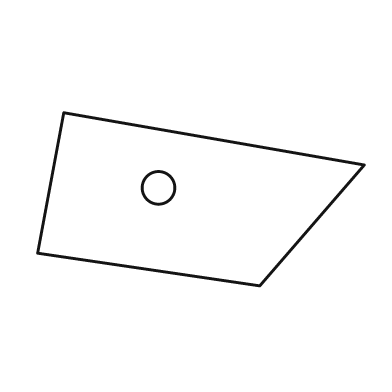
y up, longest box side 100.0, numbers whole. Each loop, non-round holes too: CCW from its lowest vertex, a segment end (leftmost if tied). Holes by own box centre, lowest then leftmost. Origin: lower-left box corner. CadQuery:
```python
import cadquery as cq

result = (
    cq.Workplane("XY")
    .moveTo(68.0, 0.0)
    .lineTo(100.0, 37.0)
    .lineTo(8.0, 53.0)
    .lineTo(0.0, 10.0)
    .close()
    .moveTo(37.0, 30.0)
    .circle(5.0)
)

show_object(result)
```